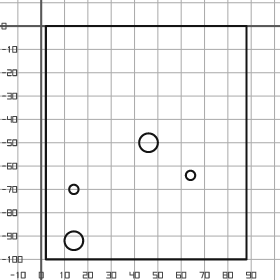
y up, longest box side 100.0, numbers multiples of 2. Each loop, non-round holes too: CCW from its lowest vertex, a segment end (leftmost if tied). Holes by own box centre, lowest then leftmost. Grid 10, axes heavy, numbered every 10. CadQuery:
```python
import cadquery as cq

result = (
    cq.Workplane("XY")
    .moveTo(2.0, -100.0)
    .lineTo(88.0, -100.0)
    .lineTo(88.0, 0.0)
    .lineTo(2.0, 0.0)
    .close()
    .moveTo(14.0, -92.0)
    .circle(4.0)
    .moveTo(14.0, -70.0)
    .circle(2.0)
    .moveTo(64.0, -64.0)
    .circle(2.0)
    .moveTo(46.0, -50.0)
    .circle(4.0)
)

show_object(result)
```